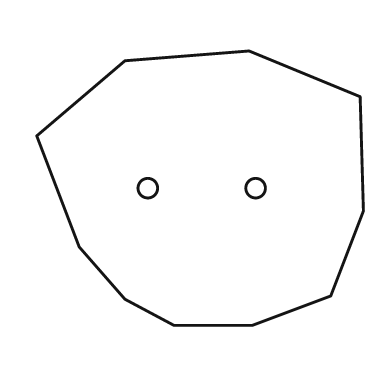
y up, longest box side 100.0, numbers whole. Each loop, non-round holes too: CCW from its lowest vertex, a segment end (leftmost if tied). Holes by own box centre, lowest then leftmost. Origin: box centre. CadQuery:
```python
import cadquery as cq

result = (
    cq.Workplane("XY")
    .moveTo(-8.0, -42.0)
    .lineTo(16.0, -42.0)
    .lineTo(40.0, -33.0)
    .lineTo(50.0, -7.0)
    .lineTo(49.0, 28.0)
    .lineTo(15.0, 42.0)
    .lineTo(-23.0, 39.0)
    .lineTo(-50.0, 16.0)
    .lineTo(-37.0, -18.0)
    .lineTo(-23.0, -34.0)
    .close()
    .moveTo(-16.0, 0.0)
    .circle(3.0)
    .moveTo(17.0, 0.0)
    .circle(3.0)
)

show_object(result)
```